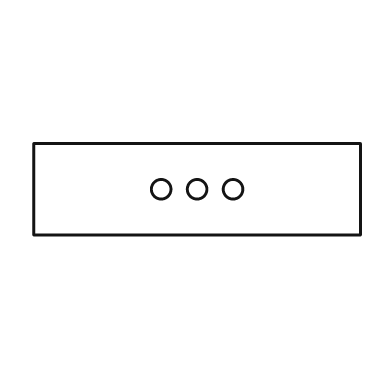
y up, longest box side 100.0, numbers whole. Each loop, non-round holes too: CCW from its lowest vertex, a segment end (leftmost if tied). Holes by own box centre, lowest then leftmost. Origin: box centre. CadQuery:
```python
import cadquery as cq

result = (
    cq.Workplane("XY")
    .moveTo(-50.0, -14.0)
    .lineTo(50.0, -14.0)
    .lineTo(50.0, 14.0)
    .lineTo(-50.0, 14.0)
    .close()
    .moveTo(-11.0, 0.0)
    .circle(3.0)
    .moveTo(0.0, 0.0)
    .circle(3.0)
    .moveTo(11.0, 0.0)
    .circle(3.0)
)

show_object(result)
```